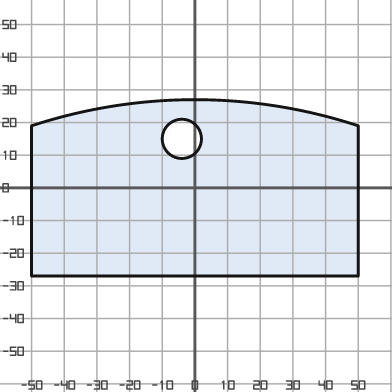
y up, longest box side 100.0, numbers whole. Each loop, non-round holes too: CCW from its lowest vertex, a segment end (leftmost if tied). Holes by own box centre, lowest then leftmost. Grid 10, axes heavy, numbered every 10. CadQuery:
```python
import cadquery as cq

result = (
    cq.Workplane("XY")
    .moveTo(-50.0, -27.0)
    .lineTo(50.0, -27.0)
    .lineTo(50.0, 19.0)
    .threePointArc((0.0, 27.0), (-50.0, 19.0))
    .close()
    .moveTo(-4.0, 15.0)
    .circle(6.0)
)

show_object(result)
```